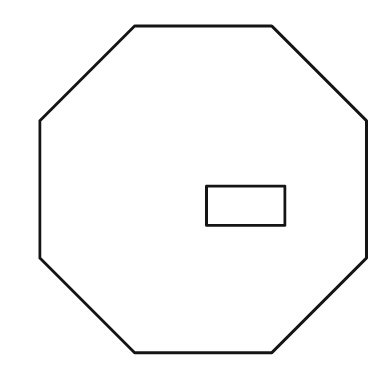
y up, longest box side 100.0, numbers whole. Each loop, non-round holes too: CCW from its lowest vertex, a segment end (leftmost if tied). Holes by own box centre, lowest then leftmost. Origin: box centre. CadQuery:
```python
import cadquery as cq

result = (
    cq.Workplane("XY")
    .moveTo(-21.0, -50.0)
    .lineTo(21.0, -50.0)
    .lineTo(50.0, -21.0)
    .lineTo(50.0, 21.0)
    .lineTo(21.0, 50.0)
    .lineTo(-21.0, 50.0)
    .lineTo(-50.0, 21.0)
    .lineTo(-50.0, -21.0)
    .close()
    .moveTo(1.0, -11.0)
    .lineTo(25.0, -11.0)
    .lineTo(25.0, 1.0)
    .lineTo(1.0, 1.0)
    .close()
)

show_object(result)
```